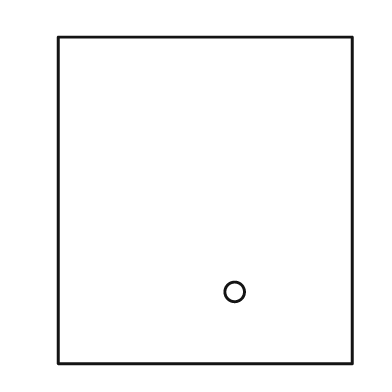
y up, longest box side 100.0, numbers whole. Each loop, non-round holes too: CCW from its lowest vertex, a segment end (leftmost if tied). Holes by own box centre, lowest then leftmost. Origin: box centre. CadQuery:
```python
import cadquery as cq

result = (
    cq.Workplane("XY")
    .moveTo(-45.0, -50.0)
    .lineTo(45.0, -50.0)
    .lineTo(45.0, 50.0)
    .lineTo(-45.0, 50.0)
    .close()
    .moveTo(9.0, -28.0)
    .circle(3.0)
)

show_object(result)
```